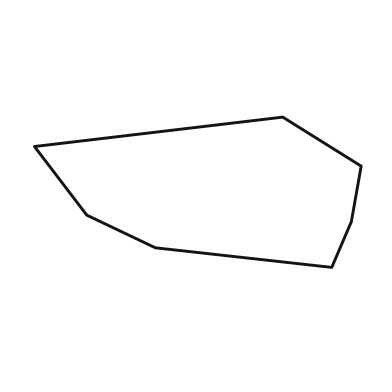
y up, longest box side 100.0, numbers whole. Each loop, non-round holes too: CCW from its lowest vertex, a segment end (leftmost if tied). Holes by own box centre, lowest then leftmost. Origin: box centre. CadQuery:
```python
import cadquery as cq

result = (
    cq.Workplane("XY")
    .moveTo(41.0, -23.0)
    .lineTo(47.0, -9.0)
    .lineTo(50.0, 8.0)
    .lineTo(26.0, 23.0)
    .lineTo(-50.0, 14.0)
    .lineTo(-34.0, -7.0)
    .lineTo(-13.0, -17.0)
    .close()
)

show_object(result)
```